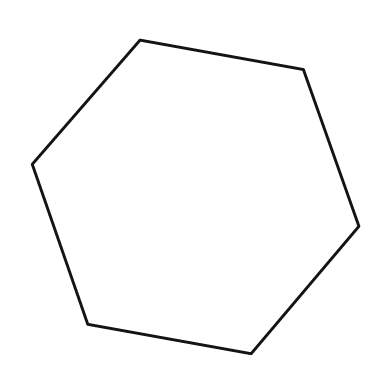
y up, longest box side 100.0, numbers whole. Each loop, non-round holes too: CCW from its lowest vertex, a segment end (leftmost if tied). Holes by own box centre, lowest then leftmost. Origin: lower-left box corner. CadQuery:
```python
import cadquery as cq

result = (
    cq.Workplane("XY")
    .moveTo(67.0, 0.0)
    .lineTo(100.0, 39.0)
    .lineTo(83.0, 87.0)
    .lineTo(33.0, 96.0)
    .lineTo(0.0, 58.0)
    .lineTo(17.0, 9.0)
    .close()
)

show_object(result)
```